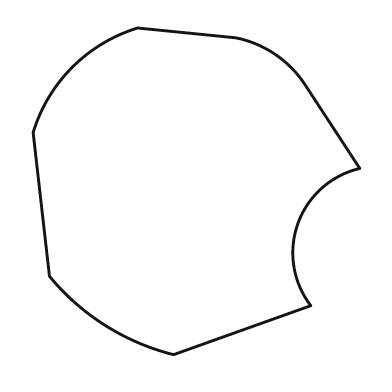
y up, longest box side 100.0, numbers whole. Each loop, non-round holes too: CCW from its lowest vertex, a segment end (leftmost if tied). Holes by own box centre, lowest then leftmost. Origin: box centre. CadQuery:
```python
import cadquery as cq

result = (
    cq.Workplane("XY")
    .moveTo(-7.0, -50.0)
    .lineTo(35.0, -35.0)
    .threePointArc((31.0, -10.0), (50.0, 7.0))
    .lineTo(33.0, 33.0)
    .threePointArc((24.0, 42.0), (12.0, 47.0))
    .lineTo(-18.0, 50.0)
    .threePointArc((-38.0, 38.0), (-50.0, 18.0))
    .lineTo(-45.0, -26.0)
    .threePointArc((-28.0, -41.0), (-7.0, -50.0))
    .close()
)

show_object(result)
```